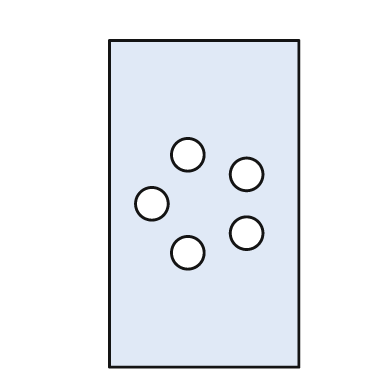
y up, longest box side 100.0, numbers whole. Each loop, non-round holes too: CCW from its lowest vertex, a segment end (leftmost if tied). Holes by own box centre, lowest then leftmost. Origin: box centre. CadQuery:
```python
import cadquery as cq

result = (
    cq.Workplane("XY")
    .moveTo(-29.0, -50.0)
    .lineTo(29.0, -50.0)
    .lineTo(29.0, 50.0)
    .lineTo(-29.0, 50.0)
    .close()
    .moveTo(-5.0, -15.0)
    .circle(5.0)
    .moveTo(13.0, -9.0)
    .circle(5.0)
    .moveTo(-16.0, 0.0)
    .circle(5.0)
    .moveTo(13.0, 9.0)
    .circle(5.0)
    .moveTo(-5.0, 15.0)
    .circle(5.0)
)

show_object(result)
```